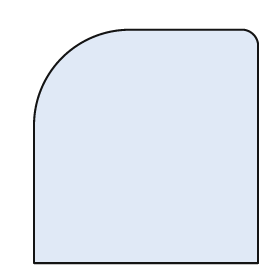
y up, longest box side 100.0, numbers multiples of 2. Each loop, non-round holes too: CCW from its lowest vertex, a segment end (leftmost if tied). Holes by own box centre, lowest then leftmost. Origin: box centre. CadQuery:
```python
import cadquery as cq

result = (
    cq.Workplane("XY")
    .moveTo(-48.0, -50.0)
    .lineTo(48.0, -50.0)
    .lineTo(48.0, 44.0)
    .threePointArc((46.0, 48.0), (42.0, 50.0))
    .lineTo(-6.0, 50.0)
    .threePointArc((-36.0, 38.0), (-48.0, 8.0))
    .close()
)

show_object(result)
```